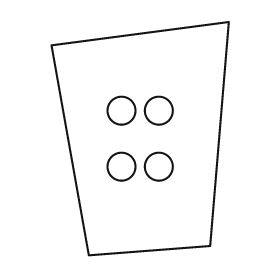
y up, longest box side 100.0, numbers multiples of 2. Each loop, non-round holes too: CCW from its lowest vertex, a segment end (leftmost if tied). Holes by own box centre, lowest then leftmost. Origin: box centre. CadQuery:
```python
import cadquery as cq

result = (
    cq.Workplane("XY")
    .moveTo(-22.0, -50.0)
    .lineTo(30.0, -46.0)
    .lineTo(38.0, 50.0)
    .lineTo(-38.0, 40.0)
    .close()
    .moveTo(-8.0, -12.0)
    .circle(6.0)
    .moveTo(8.0, -12.0)
    .circle(6.0)
    .moveTo(-8.0, 12.0)
    .circle(6.0)
    .moveTo(8.0, 12.0)
    .circle(6.0)
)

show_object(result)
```